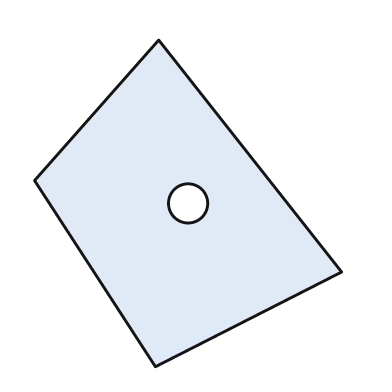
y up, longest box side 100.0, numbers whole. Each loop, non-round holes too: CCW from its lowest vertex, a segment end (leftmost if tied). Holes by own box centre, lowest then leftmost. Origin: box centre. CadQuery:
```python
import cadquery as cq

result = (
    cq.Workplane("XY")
    .moveTo(-10.0, -50.0)
    .lineTo(47.0, -21.0)
    .lineTo(-9.0, 50.0)
    .lineTo(-47.0, 7.0)
    .close()
    .moveTo(0.0, 0.0)
    .circle(6.0)
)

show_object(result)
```